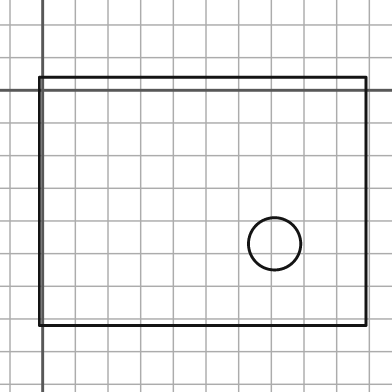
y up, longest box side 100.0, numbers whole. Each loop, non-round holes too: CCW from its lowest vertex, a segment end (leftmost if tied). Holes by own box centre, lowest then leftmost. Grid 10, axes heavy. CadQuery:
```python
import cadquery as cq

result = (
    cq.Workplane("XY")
    .moveTo(-1.0, -72.0)
    .lineTo(99.0, -72.0)
    .lineTo(99.0, 4.0)
    .lineTo(-1.0, 4.0)
    .close()
    .moveTo(71.0, -47.0)
    .circle(8.0)
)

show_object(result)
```